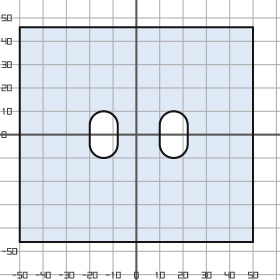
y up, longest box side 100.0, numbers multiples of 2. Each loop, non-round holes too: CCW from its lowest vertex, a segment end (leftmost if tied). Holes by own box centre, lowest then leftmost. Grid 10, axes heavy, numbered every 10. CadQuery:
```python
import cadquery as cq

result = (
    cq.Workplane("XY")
    .moveTo(-50.0, -46.0)
    .lineTo(50.0, -46.0)
    .lineTo(50.0, 46.0)
    .lineTo(-50.0, 46.0)
    .close()
    .moveTo(-20.0, -4.0)
    .threePointArc((-14.0, -10.0), (-8.0, -4.0))
    .lineTo(-8.0, 4.0)
    .threePointArc((-14.0, 10.0), (-20.0, 4.0))
    .close()
    .moveTo(10.0, -4.0)
    .threePointArc((16.0, -10.0), (22.0, -4.0))
    .lineTo(22.0, 4.0)
    .threePointArc((16.0, 10.0), (10.0, 4.0))
    .close()
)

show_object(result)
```